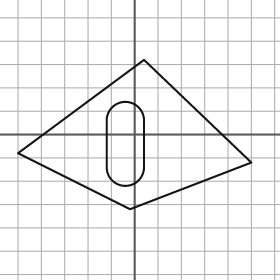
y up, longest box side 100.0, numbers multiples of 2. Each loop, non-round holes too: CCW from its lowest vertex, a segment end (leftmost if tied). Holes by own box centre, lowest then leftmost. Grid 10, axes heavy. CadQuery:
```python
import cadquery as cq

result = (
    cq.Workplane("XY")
    .moveTo(-2.0, -32.0)
    .lineTo(50.0, -12.0)
    .lineTo(4.0, 32.0)
    .lineTo(-50.0, -8.0)
    .close()
    .moveTo(-12.0, -14.0)
    .threePointArc((-4.0, -22.0), (4.0, -14.0))
    .lineTo(4.0, 6.0)
    .threePointArc((-4.0, 14.0), (-12.0, 6.0))
    .close()
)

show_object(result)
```